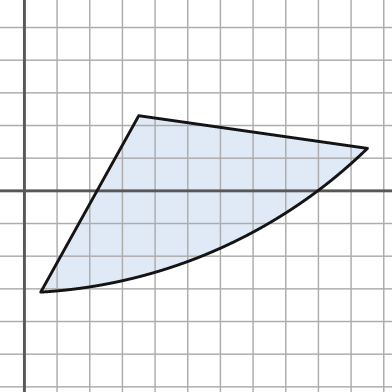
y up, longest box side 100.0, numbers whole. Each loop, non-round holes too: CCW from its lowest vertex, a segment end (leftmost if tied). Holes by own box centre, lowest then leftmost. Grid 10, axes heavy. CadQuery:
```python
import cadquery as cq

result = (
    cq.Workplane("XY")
    .moveTo(5.0, -31.0)
    .threePointArc((59.0, -18.0), (105.0, 13.0))
    .lineTo(35.0, 23.0)
    .close()
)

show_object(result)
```